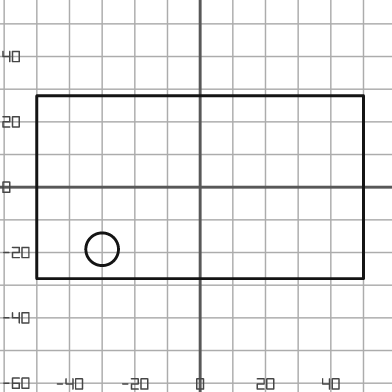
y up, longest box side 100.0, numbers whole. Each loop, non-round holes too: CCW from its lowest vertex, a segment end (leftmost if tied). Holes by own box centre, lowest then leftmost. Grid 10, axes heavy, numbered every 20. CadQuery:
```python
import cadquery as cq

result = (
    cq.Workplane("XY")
    .moveTo(-50.0, -28.0)
    .lineTo(50.0, -28.0)
    .lineTo(50.0, 28.0)
    .lineTo(-50.0, 28.0)
    .close()
    .moveTo(-30.0, -19.0)
    .circle(5.0)
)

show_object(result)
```